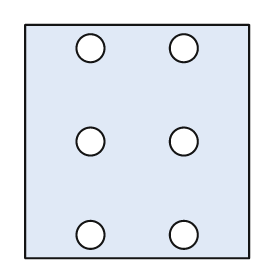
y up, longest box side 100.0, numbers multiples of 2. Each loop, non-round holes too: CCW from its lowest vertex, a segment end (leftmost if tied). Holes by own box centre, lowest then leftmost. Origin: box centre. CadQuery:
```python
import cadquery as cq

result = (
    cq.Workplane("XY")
    .moveTo(-48.0, -50.0)
    .lineTo(48.0, -50.0)
    .lineTo(48.0, 50.0)
    .lineTo(-48.0, 50.0)
    .close()
    .moveTo(-20.0, -40.0)
    .circle(6.0)
    .moveTo(20.0, -40.0)
    .circle(6.0)
    .moveTo(-20.0, 0.0)
    .circle(6.0)
    .moveTo(20.0, 0.0)
    .circle(6.0)
    .moveTo(-20.0, 40.0)
    .circle(6.0)
    .moveTo(20.0, 40.0)
    .circle(6.0)
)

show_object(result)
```